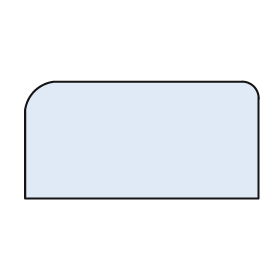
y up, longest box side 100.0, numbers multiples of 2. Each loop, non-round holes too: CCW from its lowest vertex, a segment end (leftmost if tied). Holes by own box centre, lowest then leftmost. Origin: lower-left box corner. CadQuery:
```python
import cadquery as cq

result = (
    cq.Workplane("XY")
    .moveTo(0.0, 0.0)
    .lineTo(100.0, 0.0)
    .lineTo(100.0, 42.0)
    .threePointArc((98.0, 48.0), (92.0, 50.0))
    .lineTo(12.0, 50.0)
    .threePointArc((4.0, 46.0), (0.0, 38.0))
    .close()
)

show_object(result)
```